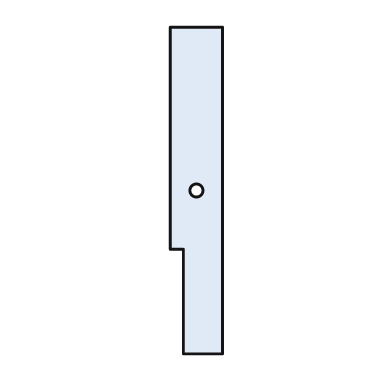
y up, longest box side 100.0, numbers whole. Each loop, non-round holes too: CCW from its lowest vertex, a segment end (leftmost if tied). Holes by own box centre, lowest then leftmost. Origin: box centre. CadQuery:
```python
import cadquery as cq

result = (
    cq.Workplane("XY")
    .moveTo(-4.0, -50.0)
    .lineTo(8.0, -50.0)
    .lineTo(8.0, 50.0)
    .lineTo(-8.0, 50.0)
    .lineTo(-8.0, -18.0)
    .lineTo(-4.0, -18.0)
    .close()
    .moveTo(0.0, 0.0)
    .circle(2.0)
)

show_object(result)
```